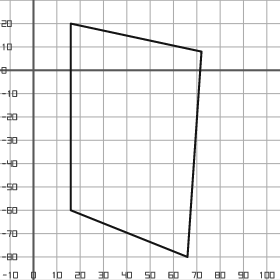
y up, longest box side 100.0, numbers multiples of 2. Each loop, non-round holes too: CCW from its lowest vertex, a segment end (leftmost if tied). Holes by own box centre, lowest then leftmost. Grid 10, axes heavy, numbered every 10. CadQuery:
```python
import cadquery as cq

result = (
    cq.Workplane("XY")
    .moveTo(66.0, -80.0)
    .lineTo(72.0, 8.0)
    .lineTo(16.0, 20.0)
    .lineTo(16.0, -60.0)
    .close()
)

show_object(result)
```